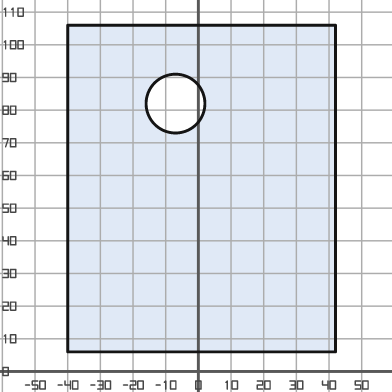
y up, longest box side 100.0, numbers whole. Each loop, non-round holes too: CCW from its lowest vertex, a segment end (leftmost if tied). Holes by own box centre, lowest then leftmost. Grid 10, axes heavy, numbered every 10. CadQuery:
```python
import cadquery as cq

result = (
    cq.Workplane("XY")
    .moveTo(-40.0, 6.0)
    .lineTo(42.0, 6.0)
    .lineTo(42.0, 106.0)
    .lineTo(-40.0, 106.0)
    .close()
    .moveTo(-7.0, 82.0)
    .circle(9.0)
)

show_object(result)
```